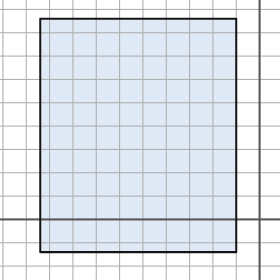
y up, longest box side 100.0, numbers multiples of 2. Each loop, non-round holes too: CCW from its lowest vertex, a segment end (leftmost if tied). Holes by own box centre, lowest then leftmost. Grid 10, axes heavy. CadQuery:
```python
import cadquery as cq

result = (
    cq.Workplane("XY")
    .moveTo(-94.0, -14.0)
    .lineTo(-10.0, -14.0)
    .lineTo(-10.0, 86.0)
    .lineTo(-94.0, 86.0)
    .close()
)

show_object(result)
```